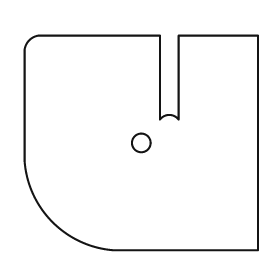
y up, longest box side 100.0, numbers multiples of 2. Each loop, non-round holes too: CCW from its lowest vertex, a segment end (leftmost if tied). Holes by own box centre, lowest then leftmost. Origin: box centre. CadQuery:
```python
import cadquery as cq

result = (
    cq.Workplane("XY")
    .moveTo(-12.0, -46.0)
    .lineTo(50.0, -46.0)
    .lineTo(50.0, 46.0)
    .lineTo(16.0, 46.0)
    .lineTo(16.0, 10.0)
    .threePointArc((12.0, 12.0), (8.0, 10.0))
    .lineTo(8.0, 46.0)
    .lineTo(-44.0, 46.0)
    .threePointArc((-48.0, 44.0), (-50.0, 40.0))
    .lineTo(-50.0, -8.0)
    .threePointArc((-38.0, -34.0), (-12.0, -46.0))
    .close()
    .moveTo(0.0, 0.0)
    .circle(4.0)
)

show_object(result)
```